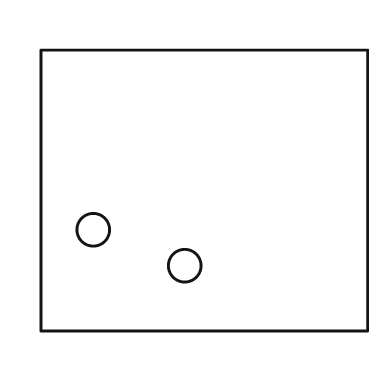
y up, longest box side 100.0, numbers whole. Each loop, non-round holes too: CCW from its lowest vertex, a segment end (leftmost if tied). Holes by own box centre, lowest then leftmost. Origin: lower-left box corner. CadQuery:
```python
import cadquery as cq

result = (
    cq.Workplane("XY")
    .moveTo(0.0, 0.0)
    .lineTo(100.0, 0.0)
    .lineTo(100.0, 86.0)
    .lineTo(0.0, 86.0)
    .close()
    .moveTo(44.0, 20.0)
    .circle(5.0)
    .moveTo(16.0, 31.0)
    .circle(5.0)
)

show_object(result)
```